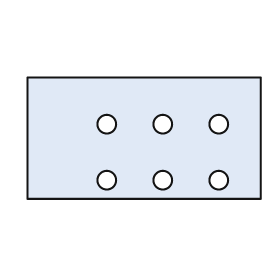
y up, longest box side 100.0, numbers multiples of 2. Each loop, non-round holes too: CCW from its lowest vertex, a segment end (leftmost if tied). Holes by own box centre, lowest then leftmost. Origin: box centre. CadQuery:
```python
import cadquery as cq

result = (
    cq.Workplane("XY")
    .moveTo(-50.0, -26.0)
    .lineTo(50.0, -26.0)
    .lineTo(50.0, 26.0)
    .lineTo(-50.0, 26.0)
    .close()
    .moveTo(-16.0, -18.0)
    .circle(4.0)
    .moveTo(8.0, -18.0)
    .circle(4.0)
    .moveTo(32.0, -18.0)
    .circle(4.0)
    .moveTo(-16.0, 6.0)
    .circle(4.0)
    .moveTo(8.0, 6.0)
    .circle(4.0)
    .moveTo(32.0, 6.0)
    .circle(4.0)
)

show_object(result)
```